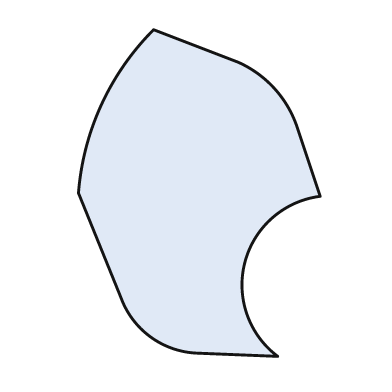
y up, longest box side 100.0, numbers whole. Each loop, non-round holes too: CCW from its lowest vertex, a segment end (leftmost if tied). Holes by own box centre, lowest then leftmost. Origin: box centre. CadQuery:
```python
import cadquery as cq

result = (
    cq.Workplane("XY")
    .moveTo(24.0, -50.0)
    .threePointArc((14.0, -21.0), (37.0, -1.0))
    .lineTo(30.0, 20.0)
    .threePointArc((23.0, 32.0), (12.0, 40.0))
    .lineTo(-14.0, 50.0)
    .threePointArc((-30.0, 27.0), (-37.0, 0.0))
    .lineTo(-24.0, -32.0)
    .threePointArc((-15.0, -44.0), (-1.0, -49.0))
    .close()
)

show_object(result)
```